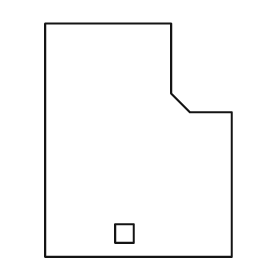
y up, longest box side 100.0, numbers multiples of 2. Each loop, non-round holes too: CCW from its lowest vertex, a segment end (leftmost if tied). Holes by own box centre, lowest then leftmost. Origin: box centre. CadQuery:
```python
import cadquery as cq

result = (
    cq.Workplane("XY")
    .moveTo(-40.0, -50.0)
    .lineTo(40.0, -50.0)
    .lineTo(40.0, 12.0)
    .lineTo(22.0, 12.0)
    .lineTo(14.0, 20.0)
    .lineTo(14.0, 50.0)
    .lineTo(-40.0, 50.0)
    .close()
    .moveTo(-10.0, -44.0)
    .lineTo(-2.0, -44.0)
    .lineTo(-2.0, -36.0)
    .lineTo(-10.0, -36.0)
    .close()
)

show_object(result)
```